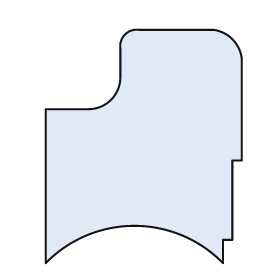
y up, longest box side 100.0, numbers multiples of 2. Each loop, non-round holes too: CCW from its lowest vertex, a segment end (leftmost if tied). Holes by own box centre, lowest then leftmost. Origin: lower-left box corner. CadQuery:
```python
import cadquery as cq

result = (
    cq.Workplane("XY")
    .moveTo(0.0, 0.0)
    .threePointArc((38.0, 16.0), (76.0, 0.0))
    .lineTo(76.0, 10.0)
    .lineTo(80.0, 10.0)
    .lineTo(80.0, 44.0)
    .lineTo(84.0, 44.0)
    .lineTo(84.0, 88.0)
    .threePointArc((80.0, 96.0), (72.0, 100.0))
    .lineTo(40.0, 100.0)
    .threePointArc((34.0, 98.0), (32.0, 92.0))
    .lineTo(32.0, 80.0)
    .threePointArc((28.0, 70.0), (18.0, 66.0))
    .lineTo(0.0, 66.0)
    .close()
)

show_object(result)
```